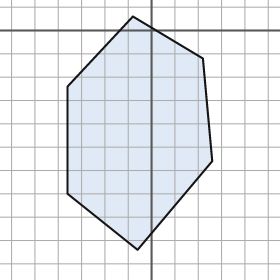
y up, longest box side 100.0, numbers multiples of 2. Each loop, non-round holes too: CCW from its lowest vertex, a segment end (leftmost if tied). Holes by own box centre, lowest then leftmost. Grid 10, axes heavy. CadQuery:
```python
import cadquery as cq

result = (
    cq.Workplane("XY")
    .moveTo(-6.0, -94.0)
    .lineTo(26.0, -56.0)
    .lineTo(22.0, -12.0)
    .lineTo(-8.0, 6.0)
    .lineTo(-36.0, -24.0)
    .lineTo(-36.0, -70.0)
    .close()
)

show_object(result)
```